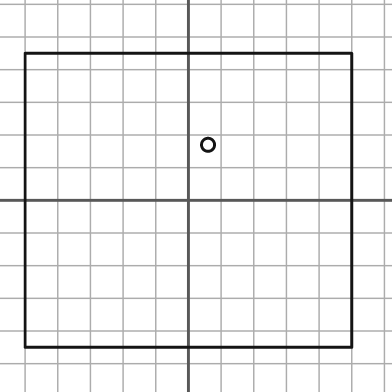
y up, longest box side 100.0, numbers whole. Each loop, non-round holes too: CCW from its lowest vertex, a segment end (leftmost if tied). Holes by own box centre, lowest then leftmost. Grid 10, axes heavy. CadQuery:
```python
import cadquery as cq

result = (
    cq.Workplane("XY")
    .moveTo(-50.0, -45.0)
    .lineTo(50.0, -45.0)
    .lineTo(50.0, 45.0)
    .lineTo(-50.0, 45.0)
    .close()
    .moveTo(6.0, 17.0)
    .circle(2.0)
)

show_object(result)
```